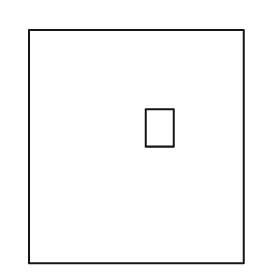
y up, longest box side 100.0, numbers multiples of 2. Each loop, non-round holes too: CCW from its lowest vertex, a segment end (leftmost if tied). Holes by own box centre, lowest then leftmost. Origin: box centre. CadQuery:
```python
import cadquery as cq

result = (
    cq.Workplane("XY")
    .moveTo(-46.0, -50.0)
    .lineTo(46.0, -50.0)
    .lineTo(46.0, 50.0)
    .lineTo(-46.0, 50.0)
    .close()
    .moveTo(4.0, 0.0)
    .lineTo(16.0, 0.0)
    .lineTo(16.0, 16.0)
    .lineTo(4.0, 16.0)
    .close()
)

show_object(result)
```